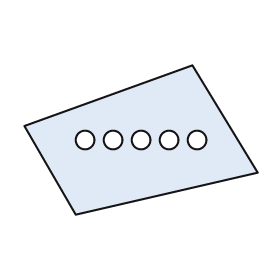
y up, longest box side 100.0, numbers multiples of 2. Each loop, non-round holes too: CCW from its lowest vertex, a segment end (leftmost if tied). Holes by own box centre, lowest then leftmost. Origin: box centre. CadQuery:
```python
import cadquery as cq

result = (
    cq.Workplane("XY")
    .moveTo(-28.0, -32.0)
    .lineTo(50.0, -14.0)
    .lineTo(22.0, 32.0)
    .lineTo(-50.0, 6.0)
    .close()
    .moveTo(-24.0, 0.0)
    .circle(4.0)
    .moveTo(-12.0, 0.0)
    .circle(4.0)
    .moveTo(0.0, 0.0)
    .circle(4.0)
    .moveTo(12.0, 0.0)
    .circle(4.0)
    .moveTo(24.0, 0.0)
    .circle(4.0)
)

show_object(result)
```